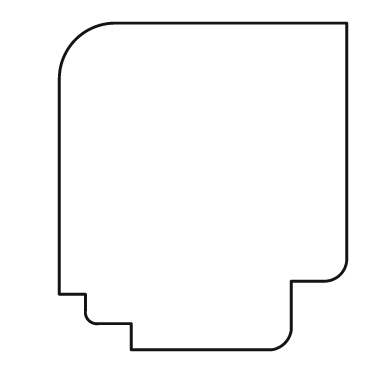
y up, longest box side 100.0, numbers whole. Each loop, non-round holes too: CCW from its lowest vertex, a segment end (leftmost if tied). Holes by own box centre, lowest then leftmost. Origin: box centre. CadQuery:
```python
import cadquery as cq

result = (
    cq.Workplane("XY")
    .moveTo(-22.0, -50.0)
    .lineTo(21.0, -50.0)
    .threePointArc((25.0, -48.0), (27.0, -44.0))
    .lineTo(27.0, -29.0)
    .lineTo(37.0, -29.0)
    .threePointArc((42.0, -27.0), (44.0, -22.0))
    .lineTo(44.0, 50.0)
    .lineTo(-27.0, 50.0)
    .threePointArc((-39.0, 45.0), (-44.0, 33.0))
    .lineTo(-44.0, -33.0)
    .lineTo(-36.0, -33.0)
    .lineTo(-36.0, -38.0)
    .threePointArc((-35.0, -41.0), (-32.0, -42.0))
    .lineTo(-22.0, -42.0)
    .close()
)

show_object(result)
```